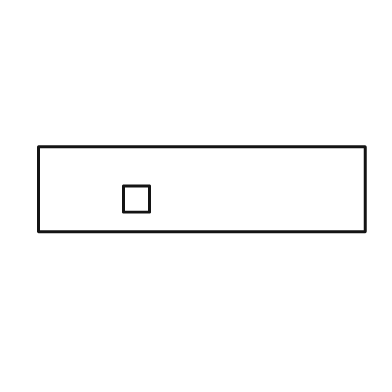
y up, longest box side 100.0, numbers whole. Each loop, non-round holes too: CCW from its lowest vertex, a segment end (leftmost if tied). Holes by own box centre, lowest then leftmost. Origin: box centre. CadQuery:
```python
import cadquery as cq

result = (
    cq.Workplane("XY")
    .moveTo(-50.0, -13.0)
    .lineTo(50.0, -13.0)
    .lineTo(50.0, 13.0)
    .lineTo(-50.0, 13.0)
    .close()
    .moveTo(-24.0, -7.0)
    .lineTo(-16.0, -7.0)
    .lineTo(-16.0, 1.0)
    .lineTo(-24.0, 1.0)
    .close()
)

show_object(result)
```